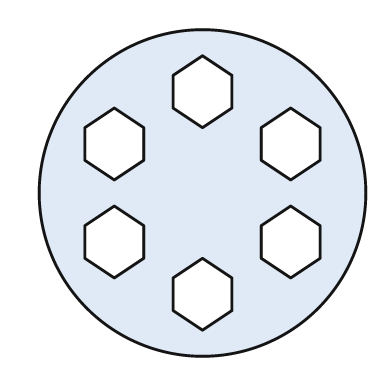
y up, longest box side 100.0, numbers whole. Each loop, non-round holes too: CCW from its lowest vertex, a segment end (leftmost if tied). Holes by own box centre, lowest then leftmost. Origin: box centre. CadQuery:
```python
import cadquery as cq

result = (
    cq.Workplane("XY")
    .moveTo(0.0, 0.0)
    .circle(50.0)
    .moveTo(0.0, -42.0)
    .lineTo(9.0, -36.0)
    .lineTo(9.0, -26.0)
    .lineTo(0.0, -20.0)
    .lineTo(-9.0, -26.0)
    .lineTo(-9.0, -36.0)
    .close()
    .moveTo(-27.0, -26.0)
    .lineTo(-18.0, -20.0)
    .lineTo(-18.0, -10.0)
    .lineTo(-27.0, -4.0)
    .lineTo(-36.0, -10.0)
    .lineTo(-36.0, -20.0)
    .close()
    .moveTo(27.0, -26.0)
    .lineTo(36.0, -20.0)
    .lineTo(36.0, -10.0)
    .lineTo(27.0, -4.0)
    .lineTo(18.0, -10.0)
    .lineTo(18.0, -20.0)
    .close()
    .moveTo(-27.0, 4.0)
    .lineTo(-18.0, 10.0)
    .lineTo(-18.0, 20.0)
    .lineTo(-27.0, 26.0)
    .lineTo(-36.0, 20.0)
    .lineTo(-36.0, 10.0)
    .close()
    .moveTo(27.0, 4.0)
    .lineTo(36.0, 10.0)
    .lineTo(36.0, 20.0)
    .lineTo(27.0, 26.0)
    .lineTo(18.0, 20.0)
    .lineTo(18.0, 10.0)
    .close()
    .moveTo(0.0, 20.0)
    .lineTo(9.0, 26.0)
    .lineTo(9.0, 36.0)
    .lineTo(0.0, 42.0)
    .lineTo(-9.0, 36.0)
    .lineTo(-9.0, 26.0)
    .close()
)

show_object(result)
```